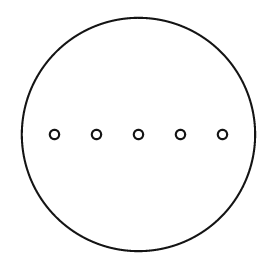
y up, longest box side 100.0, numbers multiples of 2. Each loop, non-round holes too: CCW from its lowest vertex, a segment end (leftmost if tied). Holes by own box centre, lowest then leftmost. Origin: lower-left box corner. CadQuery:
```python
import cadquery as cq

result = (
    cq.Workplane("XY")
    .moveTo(50.0, 50.0)
    .circle(50.0)
    .moveTo(14.0, 50.0)
    .circle(2.0)
    .moveTo(32.0, 50.0)
    .circle(2.0)
    .moveTo(50.0, 50.0)
    .circle(2.0)
    .moveTo(68.0, 50.0)
    .circle(2.0)
    .moveTo(86.0, 50.0)
    .circle(2.0)
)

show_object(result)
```